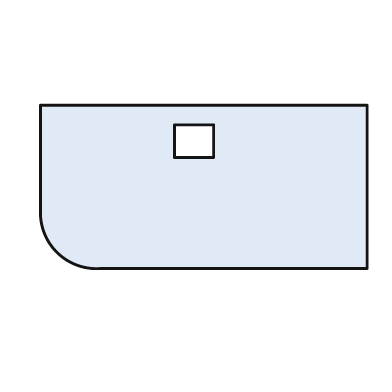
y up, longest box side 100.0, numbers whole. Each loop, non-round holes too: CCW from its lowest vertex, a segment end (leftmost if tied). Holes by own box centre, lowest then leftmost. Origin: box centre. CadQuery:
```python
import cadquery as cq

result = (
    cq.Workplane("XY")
    .moveTo(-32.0, -25.0)
    .lineTo(50.0, -25.0)
    .lineTo(50.0, 25.0)
    .lineTo(-50.0, 25.0)
    .lineTo(-50.0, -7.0)
    .threePointArc((-45.0, -20.0), (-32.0, -25.0))
    .close()
    .moveTo(-9.0, 9.0)
    .lineTo(3.0, 9.0)
    .lineTo(3.0, 19.0)
    .lineTo(-9.0, 19.0)
    .close()
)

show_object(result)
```